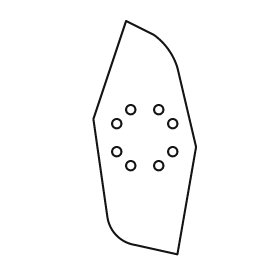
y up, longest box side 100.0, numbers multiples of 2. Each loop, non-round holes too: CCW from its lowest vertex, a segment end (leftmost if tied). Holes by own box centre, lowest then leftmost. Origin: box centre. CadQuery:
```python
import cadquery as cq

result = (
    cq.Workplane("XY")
    .moveTo(14.0, -50.0)
    .lineTo(22.0, -4.0)
    .lineTo(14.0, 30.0)
    .threePointArc((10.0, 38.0), (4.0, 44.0))
    .lineTo(-8.0, 50.0)
    .lineTo(-22.0, 8.0)
    .lineTo(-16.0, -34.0)
    .threePointArc((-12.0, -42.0), (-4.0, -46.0))
    .close()
    .moveTo(-6.0, -12.0)
    .circle(2.0)
    .moveTo(6.0, -12.0)
    .circle(2.0)
    .moveTo(-12.0, -6.0)
    .circle(2.0)
    .moveTo(12.0, -6.0)
    .circle(2.0)
    .moveTo(-12.0, 6.0)
    .circle(2.0)
    .moveTo(12.0, 6.0)
    .circle(2.0)
    .moveTo(-6.0, 12.0)
    .circle(2.0)
    .moveTo(6.0, 12.0)
    .circle(2.0)
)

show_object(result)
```